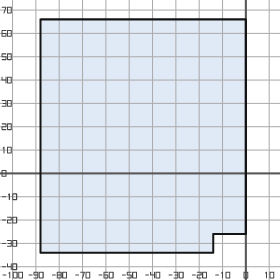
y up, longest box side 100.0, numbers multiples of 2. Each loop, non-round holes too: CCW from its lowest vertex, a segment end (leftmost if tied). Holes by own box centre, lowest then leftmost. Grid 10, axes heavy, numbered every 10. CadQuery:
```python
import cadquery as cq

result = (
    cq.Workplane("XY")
    .moveTo(-88.0, -34.0)
    .lineTo(-14.0, -34.0)
    .lineTo(-14.0, -26.0)
    .lineTo(0.0, -26.0)
    .lineTo(0.0, 66.0)
    .lineTo(-88.0, 66.0)
    .close()
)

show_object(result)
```